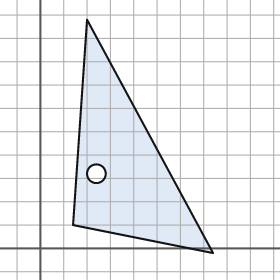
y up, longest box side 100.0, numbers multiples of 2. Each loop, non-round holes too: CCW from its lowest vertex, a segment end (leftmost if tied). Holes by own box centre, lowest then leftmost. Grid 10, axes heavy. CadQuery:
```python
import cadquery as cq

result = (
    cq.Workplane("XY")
    .moveTo(74.0, -2.0)
    .lineTo(20.0, 98.0)
    .lineTo(14.0, 10.0)
    .close()
    .moveTo(24.0, 32.0)
    .circle(4.0)
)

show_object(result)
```